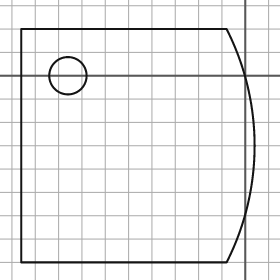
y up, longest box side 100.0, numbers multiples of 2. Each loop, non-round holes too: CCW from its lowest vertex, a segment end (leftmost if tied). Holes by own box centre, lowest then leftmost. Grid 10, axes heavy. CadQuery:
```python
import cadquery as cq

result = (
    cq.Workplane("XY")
    .moveTo(-96.0, -80.0)
    .lineTo(-8.0, -80.0)
    .threePointArc((4.0, -30.0), (-8.0, 20.0))
    .lineTo(-96.0, 20.0)
    .close()
    .moveTo(-76.0, 0.0)
    .circle(8.0)
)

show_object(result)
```